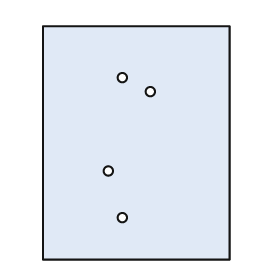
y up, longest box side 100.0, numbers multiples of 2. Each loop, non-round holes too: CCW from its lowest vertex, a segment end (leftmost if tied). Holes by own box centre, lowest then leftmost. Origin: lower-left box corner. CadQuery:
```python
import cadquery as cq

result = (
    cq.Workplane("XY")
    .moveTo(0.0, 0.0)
    .lineTo(80.0, 0.0)
    .lineTo(80.0, 100.0)
    .lineTo(0.0, 100.0)
    .close()
    .moveTo(34.0, 18.0)
    .circle(2.0)
    .moveTo(28.0, 38.0)
    .circle(2.0)
    .moveTo(46.0, 72.0)
    .circle(2.0)
    .moveTo(34.0, 78.0)
    .circle(2.0)
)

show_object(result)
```